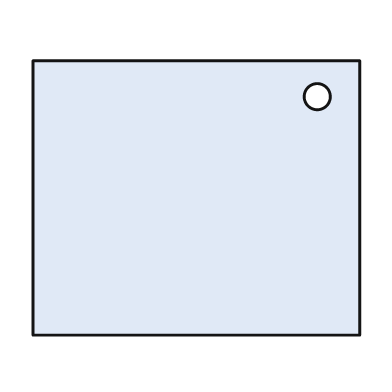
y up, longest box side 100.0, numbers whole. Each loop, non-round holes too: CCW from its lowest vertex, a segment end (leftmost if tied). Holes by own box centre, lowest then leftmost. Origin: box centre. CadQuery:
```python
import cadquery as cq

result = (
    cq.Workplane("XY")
    .moveTo(-50.0, -42.0)
    .lineTo(50.0, -42.0)
    .lineTo(50.0, 42.0)
    .lineTo(-50.0, 42.0)
    .close()
    .moveTo(37.0, 31.0)
    .circle(4.0)
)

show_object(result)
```